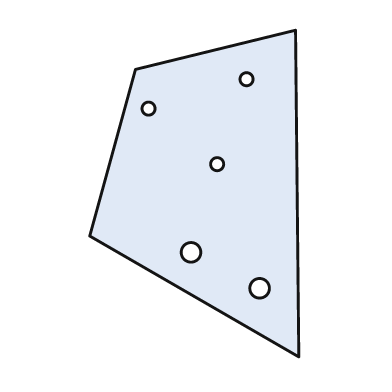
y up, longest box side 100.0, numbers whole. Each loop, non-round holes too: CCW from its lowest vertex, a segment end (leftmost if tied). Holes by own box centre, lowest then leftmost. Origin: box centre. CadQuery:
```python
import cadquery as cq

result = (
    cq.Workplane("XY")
    .moveTo(32.0, -50.0)
    .lineTo(31.0, 50.0)
    .lineTo(-18.0, 38.0)
    .lineTo(-32.0, -13.0)
    .close()
    .moveTo(20.0, -29.0)
    .circle(3.0)
    .moveTo(-1.0, -18.0)
    .circle(3.0)
    .moveTo(7.0, 9.0)
    .circle(2.0)
    .moveTo(-14.0, 26.0)
    .circle(2.0)
    .moveTo(16.0, 35.0)
    .circle(2.0)
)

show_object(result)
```